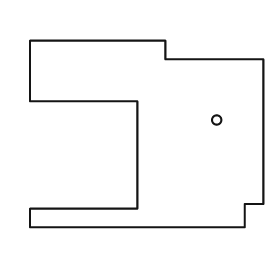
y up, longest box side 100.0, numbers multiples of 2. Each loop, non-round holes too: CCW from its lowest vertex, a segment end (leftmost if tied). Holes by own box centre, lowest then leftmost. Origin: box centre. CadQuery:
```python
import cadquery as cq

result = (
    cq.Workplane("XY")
    .moveTo(-50.0, -40.0)
    .lineTo(42.0, -40.0)
    .lineTo(42.0, -30.0)
    .lineTo(50.0, -30.0)
    .lineTo(50.0, 32.0)
    .lineTo(8.0, 32.0)
    .lineTo(8.0, 40.0)
    .lineTo(-50.0, 40.0)
    .lineTo(-50.0, 14.0)
    .lineTo(-4.0, 14.0)
    .lineTo(-4.0, -32.0)
    .lineTo(-50.0, -32.0)
    .close()
    .moveTo(30.0, 6.0)
    .circle(2.0)
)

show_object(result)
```